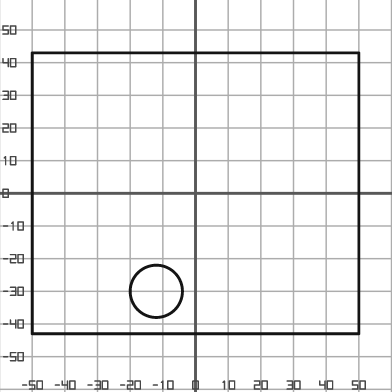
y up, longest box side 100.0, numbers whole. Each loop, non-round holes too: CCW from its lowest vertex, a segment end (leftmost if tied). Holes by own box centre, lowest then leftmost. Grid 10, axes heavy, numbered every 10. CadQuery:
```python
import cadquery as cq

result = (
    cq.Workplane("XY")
    .moveTo(-50.0, -43.0)
    .lineTo(50.0, -43.0)
    .lineTo(50.0, 43.0)
    .lineTo(-50.0, 43.0)
    .close()
    .moveTo(-12.0, -30.0)
    .circle(8.0)
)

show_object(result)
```